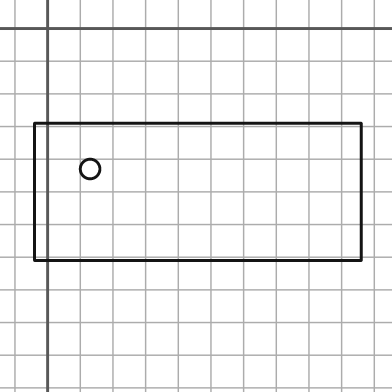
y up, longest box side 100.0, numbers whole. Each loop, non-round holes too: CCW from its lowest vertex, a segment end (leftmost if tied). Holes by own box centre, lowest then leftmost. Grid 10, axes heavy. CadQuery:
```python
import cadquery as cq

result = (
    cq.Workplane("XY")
    .moveTo(-4.0, -71.0)
    .lineTo(96.0, -71.0)
    .lineTo(96.0, -29.0)
    .lineTo(-4.0, -29.0)
    .close()
    .moveTo(13.0, -43.0)
    .circle(3.0)
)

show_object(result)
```